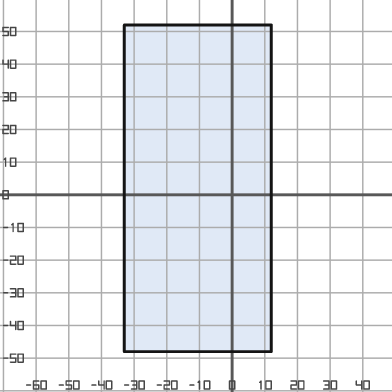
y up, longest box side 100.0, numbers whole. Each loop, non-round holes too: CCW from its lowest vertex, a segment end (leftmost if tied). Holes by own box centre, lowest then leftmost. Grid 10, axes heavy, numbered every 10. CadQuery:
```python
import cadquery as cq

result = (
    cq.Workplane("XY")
    .moveTo(-33.0, -48.0)
    .lineTo(12.0, -48.0)
    .lineTo(12.0, 52.0)
    .lineTo(-33.0, 52.0)
    .close()
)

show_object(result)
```